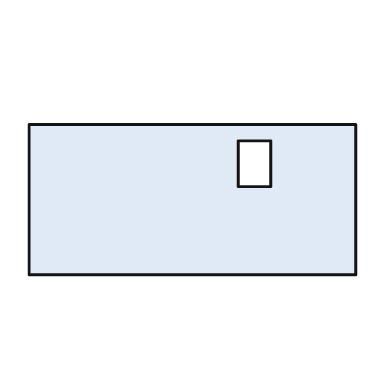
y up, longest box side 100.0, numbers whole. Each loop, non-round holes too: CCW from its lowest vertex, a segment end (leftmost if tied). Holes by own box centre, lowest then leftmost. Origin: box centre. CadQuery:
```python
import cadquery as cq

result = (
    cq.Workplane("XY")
    .moveTo(-50.0, -23.0)
    .lineTo(50.0, -23.0)
    .lineTo(50.0, 23.0)
    .lineTo(-50.0, 23.0)
    .close()
    .moveTo(14.0, 4.0)
    .lineTo(24.0, 4.0)
    .lineTo(24.0, 18.0)
    .lineTo(14.0, 18.0)
    .close()
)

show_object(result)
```